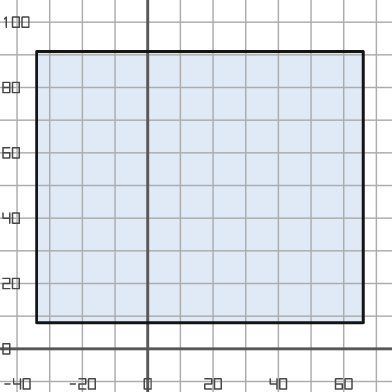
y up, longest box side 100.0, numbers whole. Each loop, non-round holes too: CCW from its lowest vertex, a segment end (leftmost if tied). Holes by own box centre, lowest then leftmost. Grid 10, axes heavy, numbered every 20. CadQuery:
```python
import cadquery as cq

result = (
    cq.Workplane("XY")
    .moveTo(-34.0, 8.0)
    .lineTo(66.0, 8.0)
    .lineTo(66.0, 91.0)
    .lineTo(-34.0, 91.0)
    .close()
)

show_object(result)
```